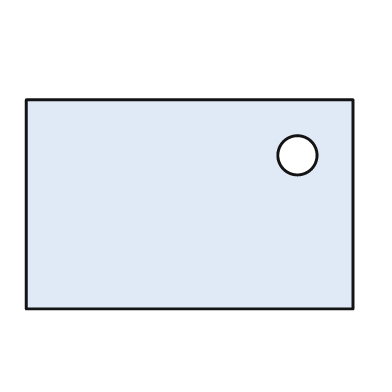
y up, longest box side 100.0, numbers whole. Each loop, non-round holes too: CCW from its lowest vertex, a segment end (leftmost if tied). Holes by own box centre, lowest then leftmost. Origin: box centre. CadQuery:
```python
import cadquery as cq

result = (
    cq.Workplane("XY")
    .moveTo(-50.0, -32.0)
    .lineTo(50.0, -32.0)
    .lineTo(50.0, 32.0)
    .lineTo(-50.0, 32.0)
    .close()
    .moveTo(33.0, 15.0)
    .circle(6.0)
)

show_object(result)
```